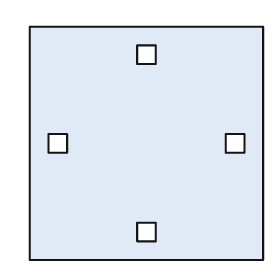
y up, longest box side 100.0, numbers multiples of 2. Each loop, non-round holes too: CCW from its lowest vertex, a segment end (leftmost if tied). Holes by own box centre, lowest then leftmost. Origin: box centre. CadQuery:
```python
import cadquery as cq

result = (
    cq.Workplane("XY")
    .moveTo(-50.0, -50.0)
    .lineTo(50.0, -50.0)
    .lineTo(50.0, 50.0)
    .lineTo(-50.0, 50.0)
    .close()
    .moveTo(-4.0, -42.0)
    .lineTo(4.0, -42.0)
    .lineTo(4.0, -34.0)
    .lineTo(-4.0, -34.0)
    .close()
    .moveTo(-42.0, -4.0)
    .lineTo(-34.0, -4.0)
    .lineTo(-34.0, 4.0)
    .lineTo(-42.0, 4.0)
    .close()
    .moveTo(34.0, -4.0)
    .lineTo(42.0, -4.0)
    .lineTo(42.0, 4.0)
    .lineTo(34.0, 4.0)
    .close()
    .moveTo(-4.0, 34.0)
    .lineTo(4.0, 34.0)
    .lineTo(4.0, 42.0)
    .lineTo(-4.0, 42.0)
    .close()
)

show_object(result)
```